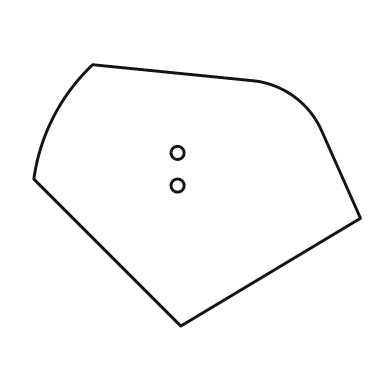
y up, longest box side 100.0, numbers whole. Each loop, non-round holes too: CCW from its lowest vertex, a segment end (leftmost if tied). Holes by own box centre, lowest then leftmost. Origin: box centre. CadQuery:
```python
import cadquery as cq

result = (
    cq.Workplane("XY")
    .moveTo(-5.0, -40.0)
    .lineTo(50.0, -7.0)
    .lineTo(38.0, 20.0)
    .threePointArc((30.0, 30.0), (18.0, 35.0))
    .lineTo(-32.0, 40.0)
    .threePointArc((-44.0, 24.0), (-50.0, 5.0))
    .close()
    .moveTo(-6.0, 3.0)
    .circle(2.0)
    .moveTo(-6.0, 13.0)
    .circle(2.0)
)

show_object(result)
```